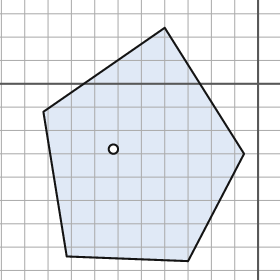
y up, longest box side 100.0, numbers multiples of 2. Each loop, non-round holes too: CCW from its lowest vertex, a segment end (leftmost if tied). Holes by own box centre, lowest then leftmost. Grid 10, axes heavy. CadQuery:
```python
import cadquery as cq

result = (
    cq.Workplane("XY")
    .moveTo(-30.0, -76.0)
    .lineTo(-6.0, -30.0)
    .lineTo(-40.0, 24.0)
    .lineTo(-92.0, -12.0)
    .lineTo(-82.0, -74.0)
    .close()
    .moveTo(-62.0, -28.0)
    .circle(2.0)
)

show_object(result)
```